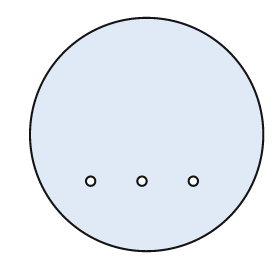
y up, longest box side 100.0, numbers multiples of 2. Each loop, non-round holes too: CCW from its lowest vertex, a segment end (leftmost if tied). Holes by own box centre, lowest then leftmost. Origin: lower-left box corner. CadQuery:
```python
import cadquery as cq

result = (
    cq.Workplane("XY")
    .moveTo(50.0, 50.0)
    .circle(50.0)
    .moveTo(26.0, 30.0)
    .circle(2.0)
    .moveTo(48.0, 30.0)
    .circle(2.0)
    .moveTo(70.0, 30.0)
    .circle(2.0)
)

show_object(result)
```